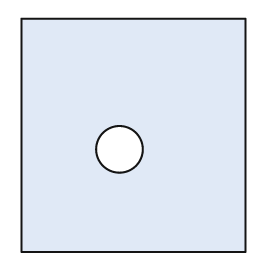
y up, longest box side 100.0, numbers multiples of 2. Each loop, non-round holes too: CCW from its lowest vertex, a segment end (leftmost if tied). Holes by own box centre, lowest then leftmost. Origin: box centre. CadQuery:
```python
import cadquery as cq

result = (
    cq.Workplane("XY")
    .moveTo(-48.0, -50.0)
    .lineTo(48.0, -50.0)
    .lineTo(48.0, 50.0)
    .lineTo(-48.0, 50.0)
    .close()
    .moveTo(-6.0, -6.0)
    .circle(10.0)
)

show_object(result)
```